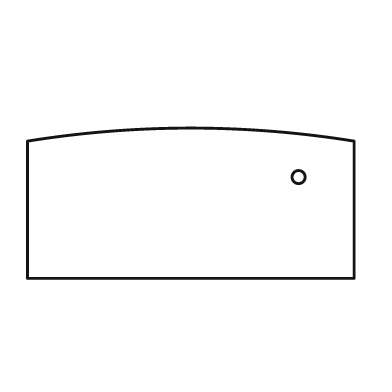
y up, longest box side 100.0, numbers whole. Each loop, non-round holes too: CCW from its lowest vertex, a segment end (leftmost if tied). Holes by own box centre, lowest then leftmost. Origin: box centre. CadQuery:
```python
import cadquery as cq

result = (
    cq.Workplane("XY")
    .moveTo(-50.0, -23.0)
    .lineTo(50.0, -23.0)
    .lineTo(50.0, 19.0)
    .threePointArc((0.0, 23.0), (-50.0, 19.0))
    .close()
    .moveTo(33.0, 8.0)
    .circle(2.0)
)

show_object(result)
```